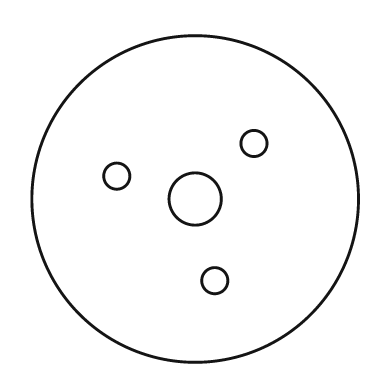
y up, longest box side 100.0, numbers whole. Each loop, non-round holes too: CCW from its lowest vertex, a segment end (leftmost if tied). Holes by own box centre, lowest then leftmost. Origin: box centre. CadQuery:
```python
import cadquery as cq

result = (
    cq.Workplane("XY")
    .moveTo(0.0, 0.0)
    .circle(50.0)
    .moveTo(6.0, -25.0)
    .circle(4.0)
    .moveTo(0.0, 0.0)
    .circle(8.0)
    .moveTo(-24.0, 7.0)
    .circle(4.0)
    .moveTo(18.0, 17.0)
    .circle(4.0)
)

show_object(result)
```